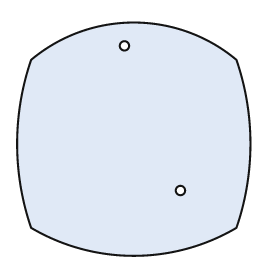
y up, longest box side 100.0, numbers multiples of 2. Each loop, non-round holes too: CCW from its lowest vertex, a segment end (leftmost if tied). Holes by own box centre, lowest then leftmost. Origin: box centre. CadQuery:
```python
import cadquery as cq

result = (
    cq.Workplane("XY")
    .moveTo(-44.0, -38.0)
    .threePointArc((0.0, -50.0), (44.0, -38.0))
    .threePointArc((50.0, -2.0), (44.0, 34.0))
    .threePointArc((0.0, 50.0), (-44.0, 34.0))
    .threePointArc((-50.0, -2.0), (-44.0, -38.0))
    .close()
    .moveTo(20.0, -22.0)
    .circle(2.0)
    .moveTo(-4.0, 40.0)
    .circle(2.0)
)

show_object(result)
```